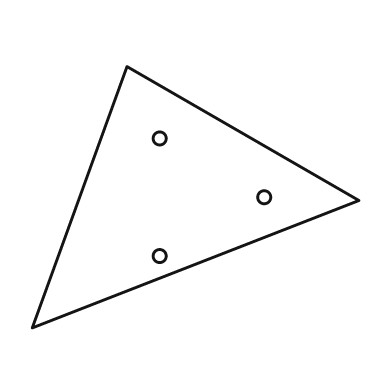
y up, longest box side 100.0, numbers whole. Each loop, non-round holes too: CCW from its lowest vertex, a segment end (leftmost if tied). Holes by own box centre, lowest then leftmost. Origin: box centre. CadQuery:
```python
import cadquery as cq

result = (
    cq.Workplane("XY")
    .moveTo(-50.0, -40.0)
    .lineTo(50.0, -1.0)
    .lineTo(-21.0, 40.0)
    .close()
    .moveTo(-11.0, -18.0)
    .circle(2.0)
    .moveTo(21.0, 0.0)
    .circle(2.0)
    .moveTo(-11.0, 18.0)
    .circle(2.0)
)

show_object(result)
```